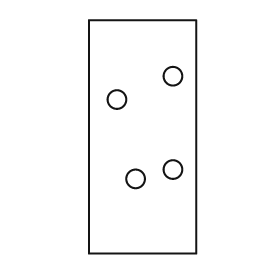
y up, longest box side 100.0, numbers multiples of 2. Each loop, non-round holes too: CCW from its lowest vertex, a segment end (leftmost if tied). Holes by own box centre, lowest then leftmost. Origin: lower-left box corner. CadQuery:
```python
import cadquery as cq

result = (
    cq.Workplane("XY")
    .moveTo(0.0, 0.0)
    .lineTo(46.0, 0.0)
    .lineTo(46.0, 100.0)
    .lineTo(0.0, 100.0)
    .close()
    .moveTo(20.0, 32.0)
    .circle(4.0)
    .moveTo(36.0, 36.0)
    .circle(4.0)
    .moveTo(12.0, 66.0)
    .circle(4.0)
    .moveTo(36.0, 76.0)
    .circle(4.0)
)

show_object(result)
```